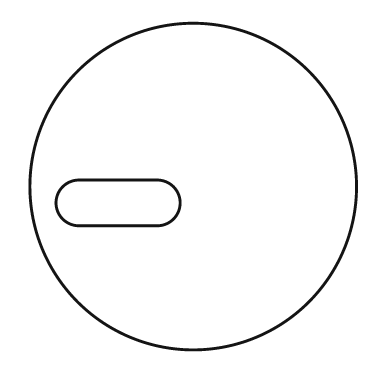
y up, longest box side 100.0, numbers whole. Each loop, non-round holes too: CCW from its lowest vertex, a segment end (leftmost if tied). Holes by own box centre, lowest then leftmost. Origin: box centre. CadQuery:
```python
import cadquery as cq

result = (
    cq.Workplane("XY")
    .moveTo(0.0, 0.0)
    .circle(50.0)
    .moveTo(-35.0, -12.0)
    .lineTo(-11.0, -12.0)
    .threePointArc((-4.0, -5.0), (-11.0, 2.0))
    .lineTo(-35.0, 2.0)
    .threePointArc((-42.0, -5.0), (-35.0, -12.0))
    .close()
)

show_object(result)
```